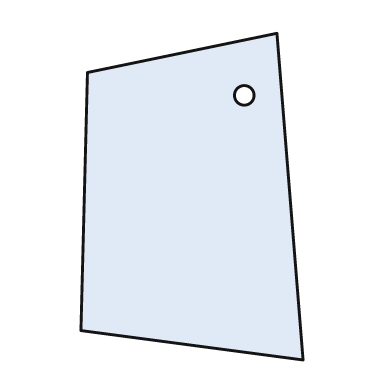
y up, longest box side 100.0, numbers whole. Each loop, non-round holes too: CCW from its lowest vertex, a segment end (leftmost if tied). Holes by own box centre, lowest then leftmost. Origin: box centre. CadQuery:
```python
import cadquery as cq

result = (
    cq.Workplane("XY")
    .moveTo(34.0, -50.0)
    .lineTo(26.0, 50.0)
    .lineTo(-32.0, 38.0)
    .lineTo(-34.0, -41.0)
    .close()
    .moveTo(16.0, 31.0)
    .circle(3.0)
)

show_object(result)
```